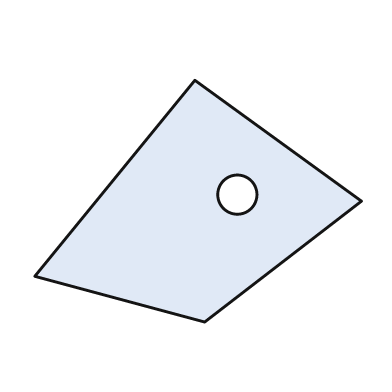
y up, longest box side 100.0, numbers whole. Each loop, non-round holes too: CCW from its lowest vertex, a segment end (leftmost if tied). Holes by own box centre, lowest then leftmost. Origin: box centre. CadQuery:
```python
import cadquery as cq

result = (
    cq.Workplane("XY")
    .moveTo(2.0, -37.0)
    .lineTo(50.0, 0.0)
    .lineTo(-1.0, 37.0)
    .lineTo(-50.0, -23.0)
    .close()
    .moveTo(12.0, 2.0)
    .circle(6.0)
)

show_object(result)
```